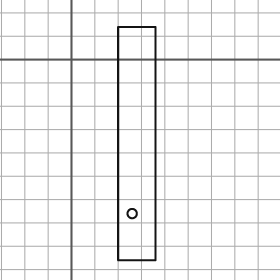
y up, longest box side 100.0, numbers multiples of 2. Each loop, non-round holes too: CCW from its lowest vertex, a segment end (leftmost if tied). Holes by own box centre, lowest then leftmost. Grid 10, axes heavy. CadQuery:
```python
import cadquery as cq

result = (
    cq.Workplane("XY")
    .moveTo(20.0, -86.0)
    .lineTo(36.0, -86.0)
    .lineTo(36.0, 14.0)
    .lineTo(20.0, 14.0)
    .close()
    .moveTo(26.0, -66.0)
    .circle(2.0)
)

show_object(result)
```